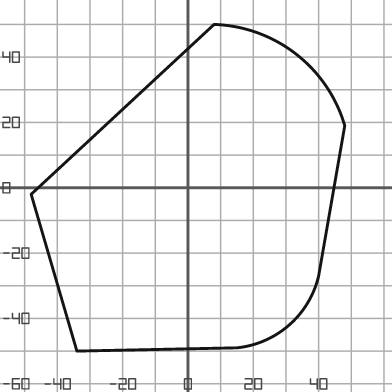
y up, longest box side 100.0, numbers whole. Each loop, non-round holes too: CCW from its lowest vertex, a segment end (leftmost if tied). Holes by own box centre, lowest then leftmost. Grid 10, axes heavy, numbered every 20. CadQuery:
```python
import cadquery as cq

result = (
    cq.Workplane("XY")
    .moveTo(-34.0, -50.0)
    .lineTo(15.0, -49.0)
    .threePointArc((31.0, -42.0), (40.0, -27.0))
    .lineTo(48.0, 19.0)
    .threePointArc((33.0, 41.0), (8.0, 50.0))
    .lineTo(-48.0, -2.0)
    .close()
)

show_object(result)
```